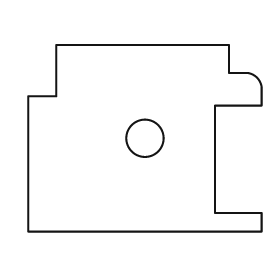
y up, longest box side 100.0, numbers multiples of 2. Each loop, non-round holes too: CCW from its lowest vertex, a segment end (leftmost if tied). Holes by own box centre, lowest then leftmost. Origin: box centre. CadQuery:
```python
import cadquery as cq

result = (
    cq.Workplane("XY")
    .moveTo(-50.0, -40.0)
    .lineTo(50.0, -40.0)
    .lineTo(50.0, -32.0)
    .lineTo(30.0, -32.0)
    .lineTo(30.0, 14.0)
    .lineTo(50.0, 14.0)
    .lineTo(50.0, 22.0)
    .threePointArc((48.0, 26.0), (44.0, 28.0))
    .lineTo(36.0, 28.0)
    .lineTo(36.0, 40.0)
    .lineTo(-38.0, 40.0)
    .lineTo(-38.0, 18.0)
    .lineTo(-50.0, 18.0)
    .close()
    .moveTo(0.0, 0.0)
    .circle(8.0)
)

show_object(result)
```